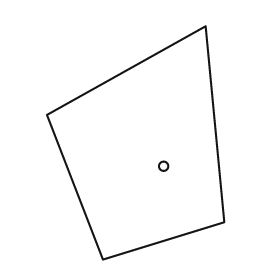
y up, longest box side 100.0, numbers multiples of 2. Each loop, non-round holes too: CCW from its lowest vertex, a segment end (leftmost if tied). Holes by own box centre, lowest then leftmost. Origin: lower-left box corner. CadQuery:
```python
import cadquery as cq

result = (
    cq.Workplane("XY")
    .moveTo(24.0, 0.0)
    .lineTo(76.0, 16.0)
    .lineTo(68.0, 100.0)
    .lineTo(0.0, 62.0)
    .close()
    .moveTo(50.0, 40.0)
    .circle(2.0)
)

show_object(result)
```